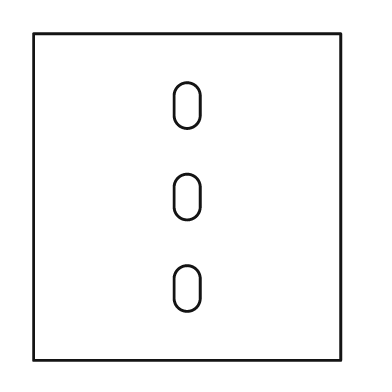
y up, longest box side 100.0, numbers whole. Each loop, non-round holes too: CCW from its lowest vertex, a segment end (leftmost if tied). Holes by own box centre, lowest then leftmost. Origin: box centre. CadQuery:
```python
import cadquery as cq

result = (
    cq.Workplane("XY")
    .moveTo(-47.0, -50.0)
    .lineTo(47.0, -50.0)
    .lineTo(47.0, 50.0)
    .lineTo(-47.0, 50.0)
    .close()
    .moveTo(-4.0, -31.0)
    .threePointArc((0.0, -35.0), (4.0, -31.0))
    .lineTo(4.0, -25.0)
    .threePointArc((0.0, -21.0), (-4.0, -25.0))
    .close()
    .moveTo(-4.0, -3.0)
    .threePointArc((0.0, -7.0), (4.0, -3.0))
    .lineTo(4.0, 3.0)
    .threePointArc((0.0, 7.0), (-4.0, 3.0))
    .close()
    .moveTo(-4.0, 25.0)
    .threePointArc((0.0, 21.0), (4.0, 25.0))
    .lineTo(4.0, 31.0)
    .threePointArc((0.0, 35.0), (-4.0, 31.0))
    .close()
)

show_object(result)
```